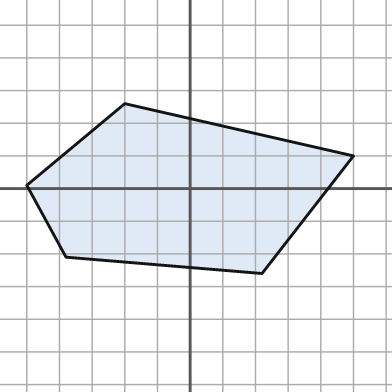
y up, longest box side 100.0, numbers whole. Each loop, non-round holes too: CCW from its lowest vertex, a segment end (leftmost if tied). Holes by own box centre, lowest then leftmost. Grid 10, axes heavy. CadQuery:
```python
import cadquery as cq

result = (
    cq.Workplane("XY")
    .moveTo(22.0, -26.0)
    .lineTo(50.0, 10.0)
    .lineTo(-20.0, 26.0)
    .lineTo(-50.0, 1.0)
    .lineTo(-38.0, -21.0)
    .close()
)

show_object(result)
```